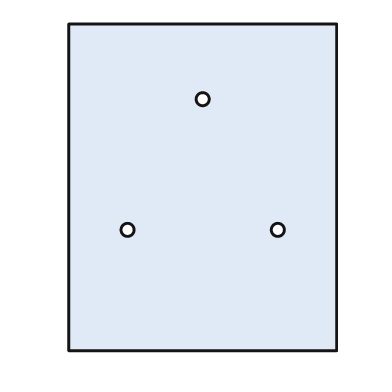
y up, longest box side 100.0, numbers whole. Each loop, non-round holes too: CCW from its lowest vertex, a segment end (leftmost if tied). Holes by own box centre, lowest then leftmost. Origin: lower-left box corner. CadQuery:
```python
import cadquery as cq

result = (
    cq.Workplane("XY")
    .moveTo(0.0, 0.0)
    .lineTo(82.0, 0.0)
    .lineTo(82.0, 100.0)
    .lineTo(0.0, 100.0)
    .close()
    .moveTo(18.0, 37.0)
    .circle(2.0)
    .moveTo(64.0, 37.0)
    .circle(2.0)
    .moveTo(41.0, 77.0)
    .circle(2.0)
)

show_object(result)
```